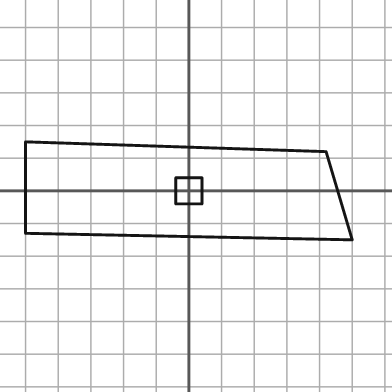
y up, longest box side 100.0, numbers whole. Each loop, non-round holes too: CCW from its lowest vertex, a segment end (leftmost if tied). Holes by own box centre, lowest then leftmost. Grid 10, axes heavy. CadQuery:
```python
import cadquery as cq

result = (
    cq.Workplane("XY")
    .moveTo(50.0, -15.0)
    .lineTo(42.0, 12.0)
    .lineTo(-50.0, 15.0)
    .lineTo(-50.0, -13.0)
    .close()
    .moveTo(-4.0, -4.0)
    .lineTo(4.0, -4.0)
    .lineTo(4.0, 4.0)
    .lineTo(-4.0, 4.0)
    .close()
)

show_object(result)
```